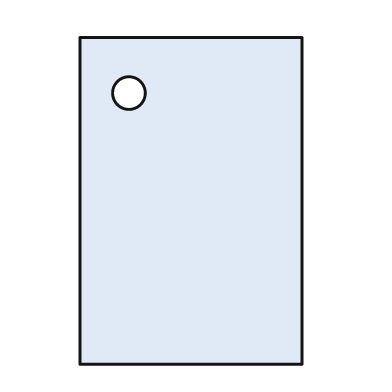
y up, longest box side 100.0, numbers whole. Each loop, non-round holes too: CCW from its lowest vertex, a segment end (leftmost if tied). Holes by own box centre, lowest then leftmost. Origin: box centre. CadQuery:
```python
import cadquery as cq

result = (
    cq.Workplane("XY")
    .moveTo(-34.0, -50.0)
    .lineTo(34.0, -50.0)
    .lineTo(34.0, 50.0)
    .lineTo(-34.0, 50.0)
    .close()
    .moveTo(-19.0, 33.0)
    .circle(5.0)
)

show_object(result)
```